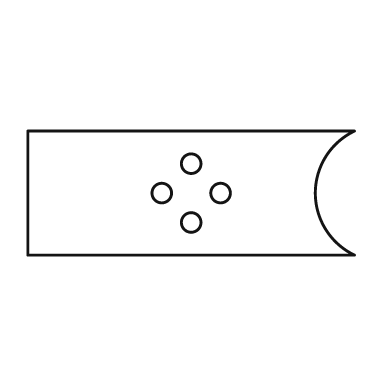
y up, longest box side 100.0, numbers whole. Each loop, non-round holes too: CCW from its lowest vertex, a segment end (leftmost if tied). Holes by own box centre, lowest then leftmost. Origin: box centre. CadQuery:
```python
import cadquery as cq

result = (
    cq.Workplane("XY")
    .moveTo(-50.0, -19.0)
    .lineTo(50.0, -19.0)
    .threePointArc((38.0, 0.0), (50.0, 19.0))
    .lineTo(-50.0, 19.0)
    .close()
    .moveTo(0.0, -9.0)
    .circle(3.0)
    .moveTo(-9.0, 0.0)
    .circle(3.0)
    .moveTo(9.0, 0.0)
    .circle(3.0)
    .moveTo(0.0, 9.0)
    .circle(3.0)
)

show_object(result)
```